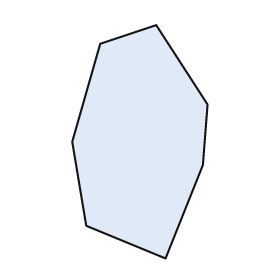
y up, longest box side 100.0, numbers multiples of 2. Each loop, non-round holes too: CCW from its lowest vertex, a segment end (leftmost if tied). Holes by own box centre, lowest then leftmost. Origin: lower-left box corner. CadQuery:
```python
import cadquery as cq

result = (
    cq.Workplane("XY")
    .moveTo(40.0, 0.0)
    .lineTo(56.0, 40.0)
    .lineTo(58.0, 66.0)
    .lineTo(36.0, 100.0)
    .lineTo(12.0, 92.0)
    .lineTo(0.0, 50.0)
    .lineTo(6.0, 14.0)
    .close()
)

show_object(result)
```